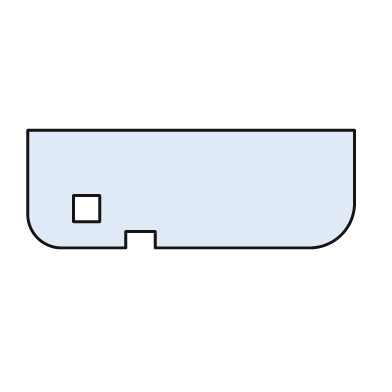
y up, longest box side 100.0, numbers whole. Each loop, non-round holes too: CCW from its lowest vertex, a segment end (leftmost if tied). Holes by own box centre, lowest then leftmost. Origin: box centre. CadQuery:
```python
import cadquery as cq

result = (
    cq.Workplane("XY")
    .moveTo(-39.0, -18.0)
    .lineTo(-20.0, -18.0)
    .lineTo(-20.0, -13.0)
    .lineTo(-11.0, -13.0)
    .lineTo(-11.0, -18.0)
    .lineTo(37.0, -18.0)
    .threePointArc((46.0, -14.0), (50.0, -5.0))
    .lineTo(50.0, 18.0)
    .lineTo(-50.0, 18.0)
    .lineTo(-50.0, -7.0)
    .threePointArc((-47.0, -15.0), (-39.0, -18.0))
    .close()
    .moveTo(-36.0, -10.0)
    .lineTo(-28.0, -10.0)
    .lineTo(-28.0, -2.0)
    .lineTo(-36.0, -2.0)
    .close()
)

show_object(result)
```